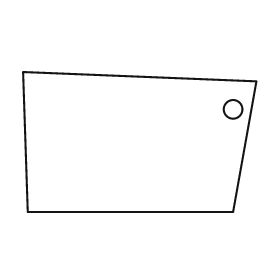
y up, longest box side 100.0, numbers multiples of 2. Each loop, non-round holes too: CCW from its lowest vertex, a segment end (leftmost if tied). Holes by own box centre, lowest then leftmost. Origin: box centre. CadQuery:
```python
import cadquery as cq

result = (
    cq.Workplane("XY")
    .moveTo(-48.0, -30.0)
    .lineTo(40.0, -30.0)
    .lineTo(50.0, 26.0)
    .lineTo(-50.0, 30.0)
    .close()
    .moveTo(40.0, 14.0)
    .circle(4.0)
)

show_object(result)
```